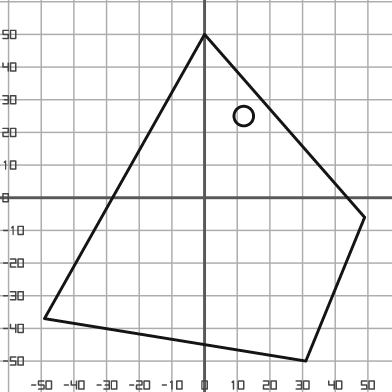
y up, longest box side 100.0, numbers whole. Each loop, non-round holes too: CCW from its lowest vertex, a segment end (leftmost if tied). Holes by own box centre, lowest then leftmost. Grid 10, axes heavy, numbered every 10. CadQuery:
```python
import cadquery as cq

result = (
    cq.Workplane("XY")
    .moveTo(31.0, -50.0)
    .lineTo(49.0, -6.0)
    .lineTo(0.0, 50.0)
    .lineTo(-49.0, -37.0)
    .close()
    .moveTo(12.0, 25.0)
    .circle(3.0)
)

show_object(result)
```